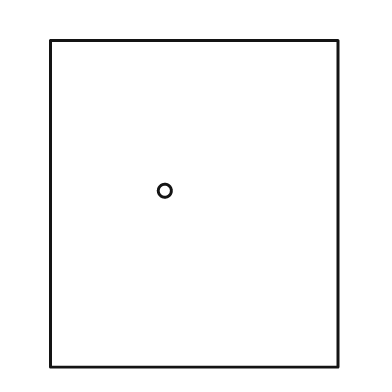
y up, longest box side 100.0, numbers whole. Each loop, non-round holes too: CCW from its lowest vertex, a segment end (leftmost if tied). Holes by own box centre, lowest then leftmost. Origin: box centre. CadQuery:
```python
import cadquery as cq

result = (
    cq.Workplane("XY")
    .moveTo(-44.0, -50.0)
    .lineTo(44.0, -50.0)
    .lineTo(44.0, 50.0)
    .lineTo(-44.0, 50.0)
    .close()
    .moveTo(-9.0, 4.0)
    .circle(2.0)
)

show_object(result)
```